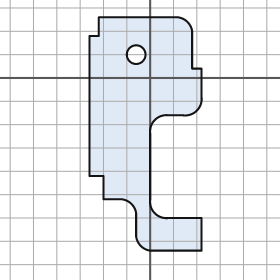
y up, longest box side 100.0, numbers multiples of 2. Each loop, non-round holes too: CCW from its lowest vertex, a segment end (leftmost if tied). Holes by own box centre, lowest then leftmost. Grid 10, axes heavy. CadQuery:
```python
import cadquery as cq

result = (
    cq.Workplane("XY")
    .moveTo(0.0, -74.0)
    .lineTo(22.0, -74.0)
    .lineTo(22.0, -60.0)
    .lineTo(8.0, -60.0)
    .threePointArc((2.0, -58.0), (0.0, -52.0))
    .lineTo(0.0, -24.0)
    .threePointArc((2.0, -18.0), (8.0, -16.0))
    .lineTo(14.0, -16.0)
    .threePointArc((20.0, -14.0), (22.0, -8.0))
    .lineTo(22.0, 4.0)
    .lineTo(18.0, 4.0)
    .lineTo(18.0, 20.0)
    .threePointArc((16.0, 24.0), (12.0, 26.0))
    .lineTo(-22.0, 26.0)
    .lineTo(-22.0, 18.0)
    .lineTo(-26.0, 18.0)
    .lineTo(-26.0, -42.0)
    .lineTo(-20.0, -42.0)
    .lineTo(-20.0, -52.0)
    .lineTo(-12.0, -52.0)
    .threePointArc((-8.0, -54.0), (-6.0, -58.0))
    .lineTo(-6.0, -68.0)
    .threePointArc((-4.0, -72.0), (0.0, -74.0))
    .close()
    .moveTo(-6.0, 10.0)
    .circle(4.0)
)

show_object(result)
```